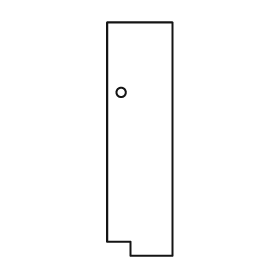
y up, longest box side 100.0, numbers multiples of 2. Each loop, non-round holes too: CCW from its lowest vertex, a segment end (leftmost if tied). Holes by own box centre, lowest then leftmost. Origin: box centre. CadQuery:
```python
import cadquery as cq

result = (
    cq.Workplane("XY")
    .moveTo(-4.0, -50.0)
    .lineTo(14.0, -50.0)
    .lineTo(14.0, 50.0)
    .lineTo(-14.0, 50.0)
    .lineTo(-14.0, -44.0)
    .lineTo(-4.0, -44.0)
    .close()
    .moveTo(-8.0, 20.0)
    .circle(2.0)
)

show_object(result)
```